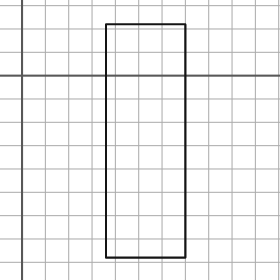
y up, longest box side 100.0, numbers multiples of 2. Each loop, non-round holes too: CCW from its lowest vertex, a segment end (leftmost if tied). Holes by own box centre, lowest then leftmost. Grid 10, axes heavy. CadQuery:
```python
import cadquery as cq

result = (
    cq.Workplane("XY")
    .moveTo(36.0, -78.0)
    .lineTo(70.0, -78.0)
    .lineTo(70.0, 22.0)
    .lineTo(36.0, 22.0)
    .close()
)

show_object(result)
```